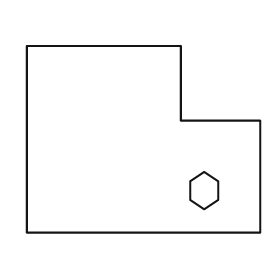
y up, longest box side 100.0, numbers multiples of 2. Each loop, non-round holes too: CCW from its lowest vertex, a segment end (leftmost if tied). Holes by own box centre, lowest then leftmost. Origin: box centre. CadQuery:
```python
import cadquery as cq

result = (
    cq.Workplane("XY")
    .moveTo(-50.0, -40.0)
    .lineTo(50.0, -40.0)
    .lineTo(50.0, 8.0)
    .lineTo(16.0, 8.0)
    .lineTo(16.0, 40.0)
    .lineTo(-50.0, 40.0)
    .close()
    .moveTo(26.0, -30.0)
    .lineTo(32.0, -26.0)
    .lineTo(32.0, -18.0)
    .lineTo(26.0, -14.0)
    .lineTo(20.0, -18.0)
    .lineTo(20.0, -26.0)
    .close()
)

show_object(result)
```